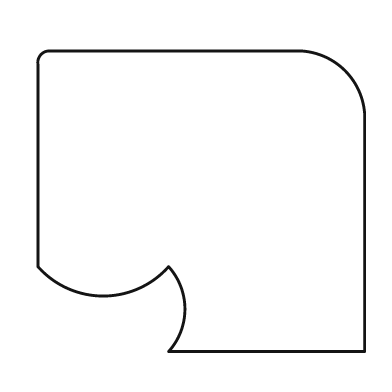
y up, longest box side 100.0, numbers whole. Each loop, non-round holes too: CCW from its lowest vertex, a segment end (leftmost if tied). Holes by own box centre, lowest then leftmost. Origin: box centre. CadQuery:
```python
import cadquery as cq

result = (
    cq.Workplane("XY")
    .moveTo(-10.0, -46.0)
    .lineTo(50.0, -46.0)
    .lineTo(50.0, 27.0)
    .threePointArc((44.0, 40.0), (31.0, 46.0))
    .lineTo(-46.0, 46.0)
    .threePointArc((-49.0, 45.0), (-50.0, 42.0))
    .lineTo(-50.0, -20.0)
    .threePointArc((-30.0, -29.0), (-10.0, -20.0))
    .threePointArc((-5.0, -33.0), (-10.0, -46.0))
    .close()
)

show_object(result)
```